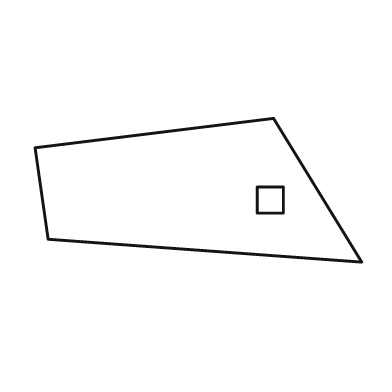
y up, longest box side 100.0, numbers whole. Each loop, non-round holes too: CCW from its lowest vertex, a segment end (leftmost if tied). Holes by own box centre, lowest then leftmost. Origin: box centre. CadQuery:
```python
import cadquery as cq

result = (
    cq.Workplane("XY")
    .moveTo(50.0, -22.0)
    .lineTo(23.0, 22.0)
    .lineTo(-50.0, 13.0)
    .lineTo(-46.0, -15.0)
    .close()
    .moveTo(18.0, -7.0)
    .lineTo(26.0, -7.0)
    .lineTo(26.0, 1.0)
    .lineTo(18.0, 1.0)
    .close()
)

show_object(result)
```